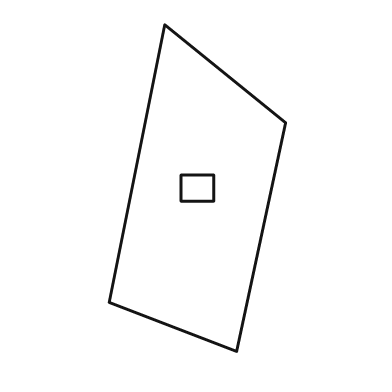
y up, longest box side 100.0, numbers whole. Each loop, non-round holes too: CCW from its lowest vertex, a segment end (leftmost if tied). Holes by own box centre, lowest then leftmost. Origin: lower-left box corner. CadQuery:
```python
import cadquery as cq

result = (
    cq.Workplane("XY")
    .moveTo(39.0, 0.0)
    .lineTo(54.0, 70.0)
    .lineTo(17.0, 100.0)
    .lineTo(0.0, 15.0)
    .close()
    .moveTo(22.0, 46.0)
    .lineTo(32.0, 46.0)
    .lineTo(32.0, 54.0)
    .lineTo(22.0, 54.0)
    .close()
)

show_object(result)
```